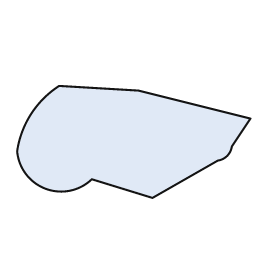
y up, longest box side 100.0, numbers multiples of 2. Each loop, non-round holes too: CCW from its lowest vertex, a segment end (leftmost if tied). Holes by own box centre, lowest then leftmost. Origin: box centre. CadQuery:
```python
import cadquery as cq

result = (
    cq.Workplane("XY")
    .moveTo(8.0, -24.0)
    .lineTo(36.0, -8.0)
    .threePointArc((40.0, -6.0), (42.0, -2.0))
    .lineTo(50.0, 10.0)
    .lineTo(2.0, 22.0)
    .lineTo(-32.0, 24.0)
    .threePointArc((-44.0, 12.0), (-50.0, -4.0))
    .threePointArc((-38.0, -20.0), (-18.0, -16.0))
    .close()
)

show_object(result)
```